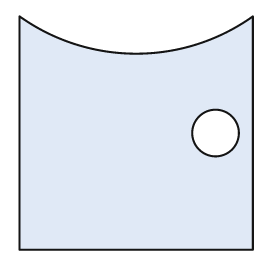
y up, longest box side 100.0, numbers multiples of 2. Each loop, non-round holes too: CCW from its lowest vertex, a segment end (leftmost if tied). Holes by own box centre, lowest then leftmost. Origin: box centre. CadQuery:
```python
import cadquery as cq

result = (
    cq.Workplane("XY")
    .moveTo(-50.0, -50.0)
    .lineTo(50.0, -50.0)
    .lineTo(50.0, 50.0)
    .threePointArc((0.0, 34.0), (-50.0, 50.0))
    .close()
    .moveTo(34.0, 0.0)
    .circle(10.0)
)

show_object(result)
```